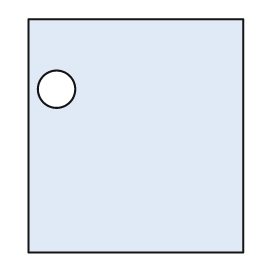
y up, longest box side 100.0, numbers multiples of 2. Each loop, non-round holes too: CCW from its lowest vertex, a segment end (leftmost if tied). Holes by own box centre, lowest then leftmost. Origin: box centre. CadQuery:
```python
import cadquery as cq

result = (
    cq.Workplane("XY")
    .moveTo(-46.0, -50.0)
    .lineTo(46.0, -50.0)
    .lineTo(46.0, 50.0)
    .lineTo(-46.0, 50.0)
    .close()
    .moveTo(-34.0, 20.0)
    .circle(8.0)
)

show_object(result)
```